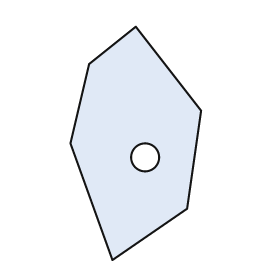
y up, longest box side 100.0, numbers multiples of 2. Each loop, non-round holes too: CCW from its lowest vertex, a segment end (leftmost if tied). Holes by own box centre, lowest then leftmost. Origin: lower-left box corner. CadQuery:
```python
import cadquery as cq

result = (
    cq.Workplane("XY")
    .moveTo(18.0, 0.0)
    .lineTo(50.0, 22.0)
    .lineTo(56.0, 64.0)
    .lineTo(28.0, 100.0)
    .lineTo(8.0, 84.0)
    .lineTo(0.0, 50.0)
    .close()
    .moveTo(32.0, 44.0)
    .circle(6.0)
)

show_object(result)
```